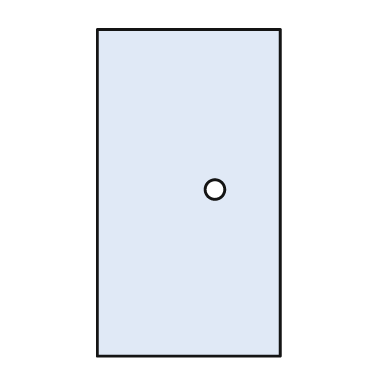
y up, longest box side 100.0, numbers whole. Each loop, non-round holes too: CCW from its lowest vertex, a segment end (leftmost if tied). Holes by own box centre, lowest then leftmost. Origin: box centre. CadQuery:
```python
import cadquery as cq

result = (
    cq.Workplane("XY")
    .moveTo(-28.0, -50.0)
    .lineTo(28.0, -50.0)
    .lineTo(28.0, 50.0)
    .lineTo(-28.0, 50.0)
    .close()
    .moveTo(8.0, 1.0)
    .circle(3.0)
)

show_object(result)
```